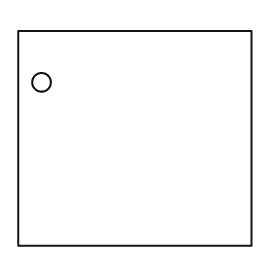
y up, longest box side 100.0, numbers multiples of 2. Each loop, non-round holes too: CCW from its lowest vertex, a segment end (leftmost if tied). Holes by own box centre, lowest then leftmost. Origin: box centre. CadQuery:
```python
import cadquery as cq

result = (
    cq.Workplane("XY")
    .moveTo(-50.0, -46.0)
    .lineTo(50.0, -46.0)
    .lineTo(50.0, 46.0)
    .lineTo(-50.0, 46.0)
    .close()
    .moveTo(-40.0, 24.0)
    .circle(4.0)
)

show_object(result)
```